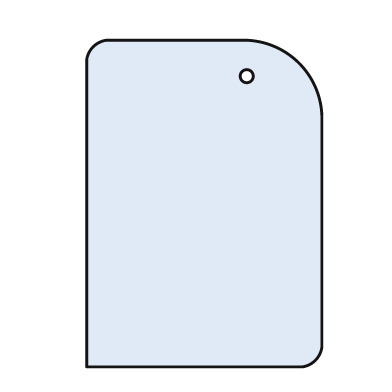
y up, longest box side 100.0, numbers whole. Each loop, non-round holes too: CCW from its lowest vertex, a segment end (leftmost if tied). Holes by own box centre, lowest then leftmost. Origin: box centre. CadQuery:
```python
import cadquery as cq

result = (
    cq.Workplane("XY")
    .moveTo(-36.0, -50.0)
    .lineTo(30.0, -50.0)
    .threePointArc((34.0, -48.0), (36.0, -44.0))
    .lineTo(36.0, 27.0)
    .threePointArc((29.0, 43.0), (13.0, 50.0))
    .lineTo(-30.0, 50.0)
    .threePointArc((-34.0, 48.0), (-36.0, 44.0))
    .close()
    .moveTo(13.0, 39.0)
    .circle(2.0)
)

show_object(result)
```